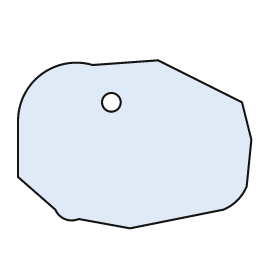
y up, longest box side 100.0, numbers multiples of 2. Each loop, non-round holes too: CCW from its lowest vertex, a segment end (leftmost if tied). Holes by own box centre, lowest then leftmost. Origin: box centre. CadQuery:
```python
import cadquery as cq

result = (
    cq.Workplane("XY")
    .moveTo(-2.0, -36.0)
    .lineTo(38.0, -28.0)
    .threePointArc((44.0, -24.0), (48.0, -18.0))
    .lineTo(50.0, 2.0)
    .lineTo(46.0, 18.0)
    .lineTo(10.0, 36.0)
    .lineTo(-18.0, 34.0)
    .threePointArc((-40.0, 30.0), (-50.0, 10.0))
    .lineTo(-50.0, -14.0)
    .lineTo(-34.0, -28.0)
    .threePointArc((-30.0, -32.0), (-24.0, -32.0))
    .close()
    .moveTo(-10.0, 18.0)
    .circle(4.0)
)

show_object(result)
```